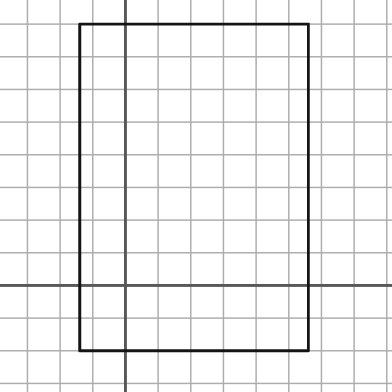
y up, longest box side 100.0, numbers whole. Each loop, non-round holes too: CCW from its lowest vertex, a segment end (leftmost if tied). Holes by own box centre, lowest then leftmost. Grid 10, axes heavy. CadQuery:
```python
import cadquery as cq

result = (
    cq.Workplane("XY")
    .moveTo(-14.0, -20.0)
    .lineTo(56.0, -20.0)
    .lineTo(56.0, 80.0)
    .lineTo(-14.0, 80.0)
    .close()
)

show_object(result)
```